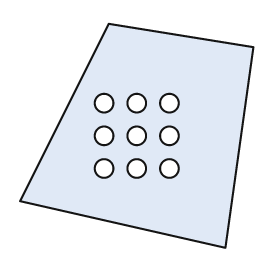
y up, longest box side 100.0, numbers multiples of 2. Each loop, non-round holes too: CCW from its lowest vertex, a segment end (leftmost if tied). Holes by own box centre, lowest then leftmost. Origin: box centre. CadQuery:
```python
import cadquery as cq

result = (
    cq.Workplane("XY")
    .moveTo(38.0, -48.0)
    .lineTo(50.0, 38.0)
    .lineTo(-12.0, 48.0)
    .lineTo(-50.0, -28.0)
    .close()
    .moveTo(-14.0, -14.0)
    .circle(4.0)
    .moveTo(0.0, -14.0)
    .circle(4.0)
    .moveTo(14.0, -14.0)
    .circle(4.0)
    .moveTo(-14.0, 0.0)
    .circle(4.0)
    .moveTo(0.0, 0.0)
    .circle(4.0)
    .moveTo(14.0, 0.0)
    .circle(4.0)
    .moveTo(-14.0, 14.0)
    .circle(4.0)
    .moveTo(0.0, 14.0)
    .circle(4.0)
    .moveTo(14.0, 14.0)
    .circle(4.0)
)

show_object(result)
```